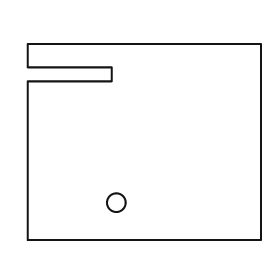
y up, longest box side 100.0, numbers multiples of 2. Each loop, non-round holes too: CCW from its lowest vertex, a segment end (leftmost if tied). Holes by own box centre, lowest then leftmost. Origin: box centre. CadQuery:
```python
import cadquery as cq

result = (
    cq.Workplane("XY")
    .moveTo(-50.0, -42.0)
    .lineTo(50.0, -42.0)
    .lineTo(50.0, 42.0)
    .lineTo(-50.0, 42.0)
    .lineTo(-50.0, 32.0)
    .lineTo(-14.0, 32.0)
    .lineTo(-14.0, 26.0)
    .lineTo(-50.0, 26.0)
    .close()
    .moveTo(-12.0, -26.0)
    .circle(4.0)
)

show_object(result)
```